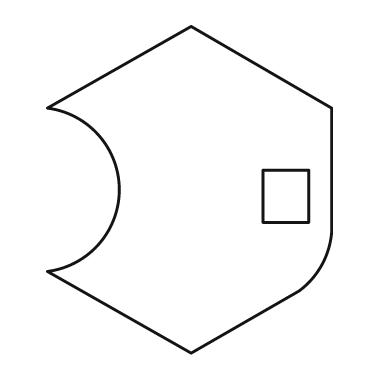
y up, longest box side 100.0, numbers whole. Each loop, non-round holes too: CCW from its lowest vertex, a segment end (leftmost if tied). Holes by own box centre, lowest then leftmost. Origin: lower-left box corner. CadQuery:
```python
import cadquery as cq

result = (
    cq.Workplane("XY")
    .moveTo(44.0, 0.0)
    .lineTo(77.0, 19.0)
    .threePointArc((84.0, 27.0), (87.0, 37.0))
    .lineTo(87.0, 75.0)
    .lineTo(44.0, 100.0)
    .lineTo(0.0, 75.0)
    .threePointArc((22.0, 50.0), (0.0, 25.0))
    .close()
    .moveTo(66.0, 40.0)
    .lineTo(80.0, 40.0)
    .lineTo(80.0, 56.0)
    .lineTo(66.0, 56.0)
    .close()
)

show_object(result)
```